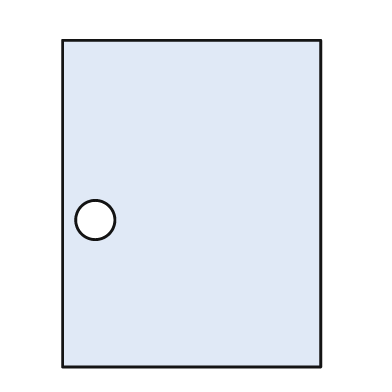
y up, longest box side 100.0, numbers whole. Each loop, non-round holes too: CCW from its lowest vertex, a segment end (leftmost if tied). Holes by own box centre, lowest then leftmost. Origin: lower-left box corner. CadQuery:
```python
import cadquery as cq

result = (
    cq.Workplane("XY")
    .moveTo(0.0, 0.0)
    .lineTo(79.0, 0.0)
    .lineTo(79.0, 100.0)
    .lineTo(0.0, 100.0)
    .close()
    .moveTo(10.0, 45.0)
    .circle(6.0)
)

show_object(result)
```